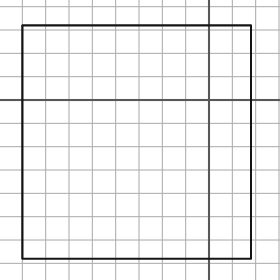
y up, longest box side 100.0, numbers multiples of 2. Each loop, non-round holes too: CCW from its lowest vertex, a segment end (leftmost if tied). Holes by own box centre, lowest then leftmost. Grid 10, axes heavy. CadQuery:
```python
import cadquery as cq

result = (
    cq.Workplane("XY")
    .moveTo(-80.0, -68.0)
    .lineTo(18.0, -68.0)
    .lineTo(18.0, 32.0)
    .lineTo(-80.0, 32.0)
    .close()
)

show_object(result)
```